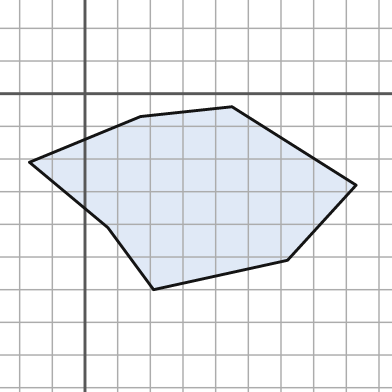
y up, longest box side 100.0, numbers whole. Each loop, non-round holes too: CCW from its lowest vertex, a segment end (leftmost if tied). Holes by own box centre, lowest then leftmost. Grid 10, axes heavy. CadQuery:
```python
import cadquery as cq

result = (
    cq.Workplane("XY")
    .moveTo(21.0, -60.0)
    .lineTo(62.0, -51.0)
    .lineTo(83.0, -28.0)
    .lineTo(45.0, -4.0)
    .lineTo(17.0, -7.0)
    .lineTo(-17.0, -21.0)
    .lineTo(7.0, -41.0)
    .close()
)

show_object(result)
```